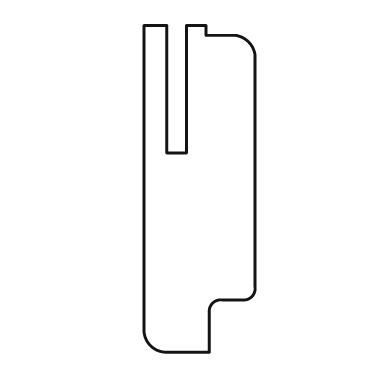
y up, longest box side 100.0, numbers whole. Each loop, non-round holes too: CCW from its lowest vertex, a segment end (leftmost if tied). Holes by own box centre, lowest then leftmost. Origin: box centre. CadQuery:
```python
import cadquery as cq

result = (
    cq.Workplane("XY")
    .moveTo(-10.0, -50.0)
    .lineTo(3.0, -50.0)
    .lineTo(3.0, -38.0)
    .threePointArc((4.0, -35.0), (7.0, -34.0))
    .lineTo(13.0, -34.0)
    .threePointArc((16.0, -33.0), (17.0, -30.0))
    .lineTo(17.0, 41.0)
    .threePointArc((15.0, 45.0), (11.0, 47.0))
    .lineTo(2.0, 47.0)
    .lineTo(2.0, 50.0)
    .lineTo(-4.0, 50.0)
    .lineTo(-4.0, 11.0)
    .lineTo(-10.0, 11.0)
    .lineTo(-10.0, 50.0)
    .lineTo(-17.0, 50.0)
    .lineTo(-17.0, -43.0)
    .threePointArc((-15.0, -48.0), (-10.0, -50.0))
    .close()
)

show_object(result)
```